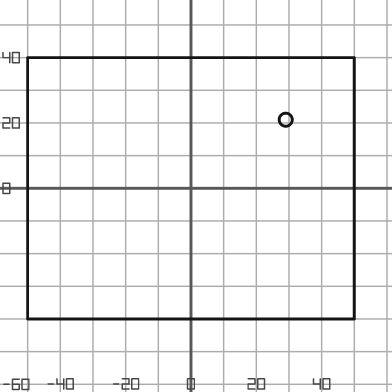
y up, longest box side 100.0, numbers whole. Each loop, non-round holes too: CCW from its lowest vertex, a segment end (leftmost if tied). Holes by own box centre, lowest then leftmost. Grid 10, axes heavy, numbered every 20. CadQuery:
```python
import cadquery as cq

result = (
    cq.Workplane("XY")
    .moveTo(-50.0, -40.0)
    .lineTo(50.0, -40.0)
    .lineTo(50.0, 40.0)
    .lineTo(-50.0, 40.0)
    .close()
    .moveTo(29.0, 21.0)
    .circle(2.0)
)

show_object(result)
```